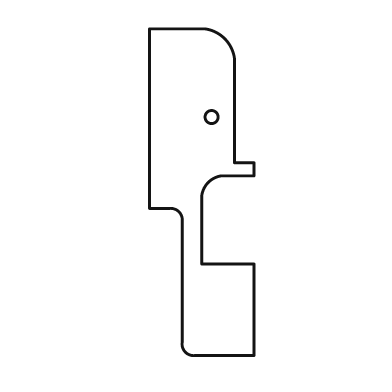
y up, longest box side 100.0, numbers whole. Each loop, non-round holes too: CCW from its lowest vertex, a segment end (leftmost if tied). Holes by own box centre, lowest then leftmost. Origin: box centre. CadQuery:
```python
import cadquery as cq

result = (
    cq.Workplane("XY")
    .moveTo(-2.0, -50.0)
    .lineTo(16.0, -50.0)
    .lineTo(16.0, -22.0)
    .lineTo(0.0, -22.0)
    .lineTo(0.0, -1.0)
    .threePointArc((2.0, 3.0), (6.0, 5.0))
    .lineTo(16.0, 5.0)
    .lineTo(16.0, 9.0)
    .lineTo(10.0, 9.0)
    .lineTo(10.0, 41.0)
    .threePointArc((7.0, 47.0), (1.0, 50.0))
    .lineTo(-16.0, 50.0)
    .lineTo(-16.0, -5.0)
    .lineTo(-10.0, -5.0)
    .threePointArc((-7.0, -6.0), (-6.0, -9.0))
    .lineTo(-6.0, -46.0)
    .threePointArc((-5.0, -49.0), (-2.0, -50.0))
    .close()
    .moveTo(3.0, 23.0)
    .circle(2.0)
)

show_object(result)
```